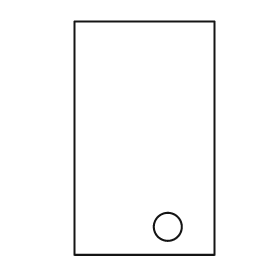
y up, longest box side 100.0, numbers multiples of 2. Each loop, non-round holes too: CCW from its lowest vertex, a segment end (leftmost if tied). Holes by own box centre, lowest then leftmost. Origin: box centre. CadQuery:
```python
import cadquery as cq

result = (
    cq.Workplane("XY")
    .moveTo(-30.0, -50.0)
    .lineTo(30.0, -50.0)
    .lineTo(30.0, 50.0)
    .lineTo(-30.0, 50.0)
    .close()
    .moveTo(10.0, -38.0)
    .circle(6.0)
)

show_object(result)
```